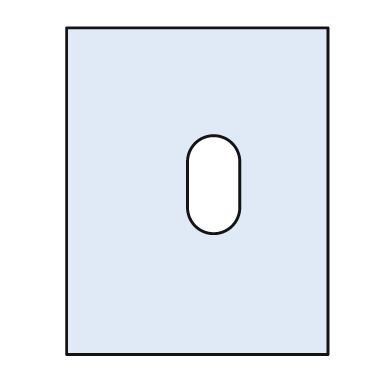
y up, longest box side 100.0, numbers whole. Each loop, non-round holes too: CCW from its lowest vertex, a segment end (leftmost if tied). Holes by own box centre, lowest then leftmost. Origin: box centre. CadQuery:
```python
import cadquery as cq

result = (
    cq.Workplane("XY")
    .moveTo(-40.0, -50.0)
    .lineTo(40.0, -50.0)
    .lineTo(40.0, 50.0)
    .lineTo(-40.0, 50.0)
    .close()
    .moveTo(-3.0, -5.0)
    .threePointArc((5.0, -13.0), (13.0, -5.0))
    .lineTo(13.0, 9.0)
    .threePointArc((5.0, 17.0), (-3.0, 9.0))
    .close()
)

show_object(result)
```